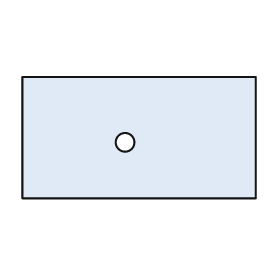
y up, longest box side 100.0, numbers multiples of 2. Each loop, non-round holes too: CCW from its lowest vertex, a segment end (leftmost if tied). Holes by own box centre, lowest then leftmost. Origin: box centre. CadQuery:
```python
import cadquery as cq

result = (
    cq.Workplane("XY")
    .moveTo(-50.0, -26.0)
    .lineTo(50.0, -26.0)
    .lineTo(50.0, 26.0)
    .lineTo(-50.0, 26.0)
    .close()
    .moveTo(-6.0, -2.0)
    .circle(4.0)
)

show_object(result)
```